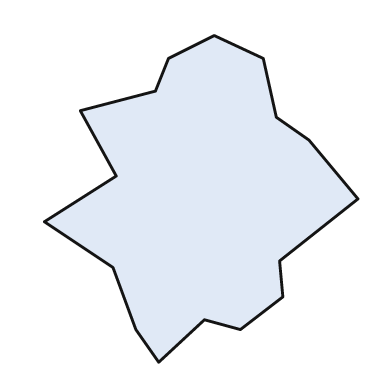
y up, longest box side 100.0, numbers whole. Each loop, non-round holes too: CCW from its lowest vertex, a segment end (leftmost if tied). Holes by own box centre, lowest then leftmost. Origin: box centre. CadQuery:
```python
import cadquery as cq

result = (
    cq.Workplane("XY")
    .moveTo(-13.0, -50.0)
    .lineTo(1.0, -37.0)
    .lineTo(12.0, -40.0)
    .lineTo(25.0, -30.0)
    .lineTo(24.0, -19.0)
    .lineTo(48.0, 0.0)
    .lineTo(33.0, 18.0)
    .lineTo(23.0, 25.0)
    .lineTo(19.0, 43.0)
    .lineTo(4.0, 50.0)
    .lineTo(-10.0, 43.0)
    .lineTo(-14.0, 33.0)
    .lineTo(-37.0, 27.0)
    .lineTo(-26.0, 7.0)
    .lineTo(-48.0, -7.0)
    .lineTo(-27.0, -21.0)
    .lineTo(-20.0, -40.0)
    .close()
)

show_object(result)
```